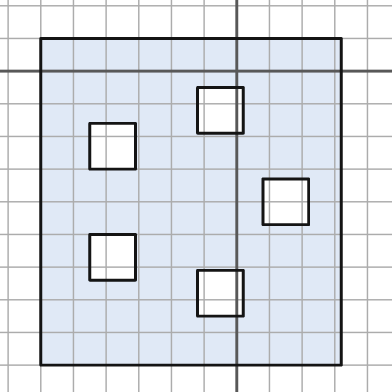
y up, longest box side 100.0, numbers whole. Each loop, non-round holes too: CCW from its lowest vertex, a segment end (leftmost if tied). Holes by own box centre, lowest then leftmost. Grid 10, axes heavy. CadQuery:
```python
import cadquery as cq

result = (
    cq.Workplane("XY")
    .moveTo(-60.0, -90.0)
    .lineTo(32.0, -90.0)
    .lineTo(32.0, 10.0)
    .lineTo(-60.0, 10.0)
    .close()
    .moveTo(-12.0, -75.0)
    .lineTo(2.0, -75.0)
    .lineTo(2.0, -61.0)
    .lineTo(-12.0, -61.0)
    .close()
    .moveTo(-45.0, -64.0)
    .lineTo(-31.0, -64.0)
    .lineTo(-31.0, -50.0)
    .lineTo(-45.0, -50.0)
    .close()
    .moveTo(8.0, -47.0)
    .lineTo(22.0, -47.0)
    .lineTo(22.0, -33.0)
    .lineTo(8.0, -33.0)
    .close()
    .moveTo(-45.0, -30.0)
    .lineTo(-31.0, -30.0)
    .lineTo(-31.0, -16.0)
    .lineTo(-45.0, -16.0)
    .close()
    .moveTo(-12.0, -19.0)
    .lineTo(2.0, -19.0)
    .lineTo(2.0, -5.0)
    .lineTo(-12.0, -5.0)
    .close()
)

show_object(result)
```